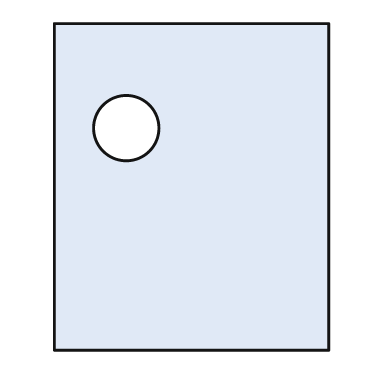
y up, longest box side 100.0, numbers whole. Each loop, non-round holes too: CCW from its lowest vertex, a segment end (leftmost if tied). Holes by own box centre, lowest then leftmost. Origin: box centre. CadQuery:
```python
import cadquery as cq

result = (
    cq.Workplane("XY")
    .moveTo(-42.0, -50.0)
    .lineTo(42.0, -50.0)
    .lineTo(42.0, 50.0)
    .lineTo(-42.0, 50.0)
    .close()
    .moveTo(-20.0, 18.0)
    .circle(10.0)
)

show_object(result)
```